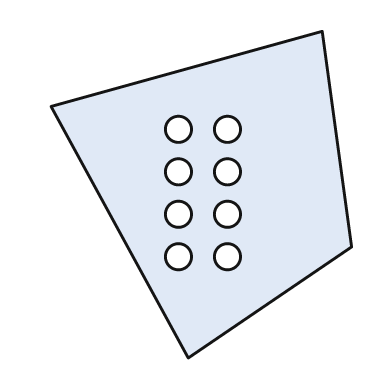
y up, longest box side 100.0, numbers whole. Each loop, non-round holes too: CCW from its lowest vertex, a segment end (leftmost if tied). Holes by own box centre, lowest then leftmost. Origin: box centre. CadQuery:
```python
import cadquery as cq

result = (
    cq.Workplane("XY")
    .moveTo(-4.0, -50.0)
    .lineTo(46.0, -16.0)
    .lineTo(37.0, 50.0)
    .lineTo(-46.0, 27.0)
    .close()
    .moveTo(-7.0, -19.0)
    .circle(4.0)
    .moveTo(8.0, -19.0)
    .circle(4.0)
    .moveTo(-7.0, -6.0)
    .circle(4.0)
    .moveTo(8.0, -6.0)
    .circle(4.0)
    .moveTo(-7.0, 7.0)
    .circle(4.0)
    .moveTo(8.0, 7.0)
    .circle(4.0)
    .moveTo(-7.0, 20.0)
    .circle(4.0)
    .moveTo(8.0, 20.0)
    .circle(4.0)
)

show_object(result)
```